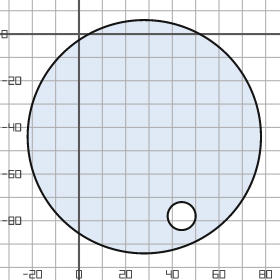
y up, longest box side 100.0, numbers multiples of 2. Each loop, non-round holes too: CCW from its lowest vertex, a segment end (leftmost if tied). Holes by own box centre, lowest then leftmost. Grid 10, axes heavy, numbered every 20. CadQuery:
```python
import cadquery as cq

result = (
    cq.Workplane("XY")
    .moveTo(28.0, -44.0)
    .circle(50.0)
    .moveTo(44.0, -78.0)
    .circle(6.0)
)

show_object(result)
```